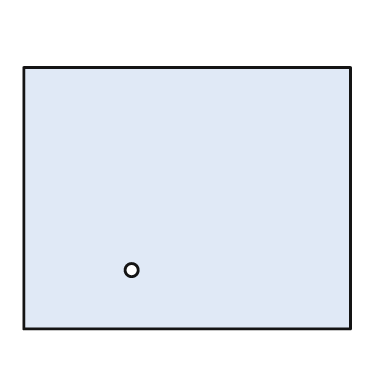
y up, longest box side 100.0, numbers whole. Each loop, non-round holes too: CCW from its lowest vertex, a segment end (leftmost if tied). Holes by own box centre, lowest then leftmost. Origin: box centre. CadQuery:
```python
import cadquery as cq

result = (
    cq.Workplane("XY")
    .moveTo(-50.0, -40.0)
    .lineTo(50.0, -40.0)
    .lineTo(50.0, 40.0)
    .lineTo(-50.0, 40.0)
    .close()
    .moveTo(-17.0, -22.0)
    .circle(2.0)
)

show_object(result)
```